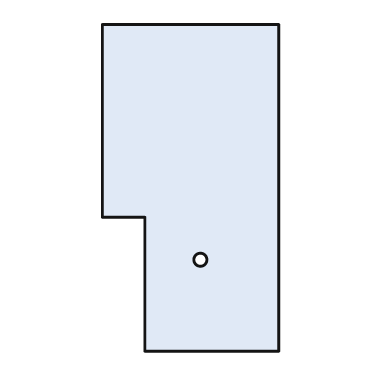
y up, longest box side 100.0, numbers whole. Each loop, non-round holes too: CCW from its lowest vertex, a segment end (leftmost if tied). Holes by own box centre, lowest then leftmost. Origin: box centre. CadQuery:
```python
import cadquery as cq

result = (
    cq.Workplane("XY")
    .moveTo(-14.0, -50.0)
    .lineTo(27.0, -50.0)
    .lineTo(27.0, 50.0)
    .lineTo(-27.0, 50.0)
    .lineTo(-27.0, -9.0)
    .lineTo(-14.0, -9.0)
    .close()
    .moveTo(3.0, -22.0)
    .circle(2.0)
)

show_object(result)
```